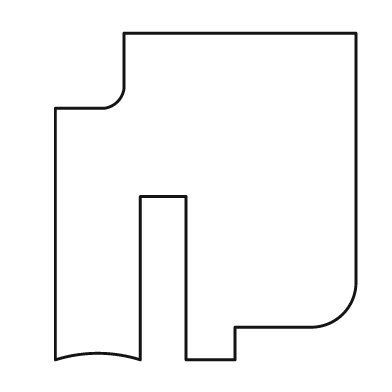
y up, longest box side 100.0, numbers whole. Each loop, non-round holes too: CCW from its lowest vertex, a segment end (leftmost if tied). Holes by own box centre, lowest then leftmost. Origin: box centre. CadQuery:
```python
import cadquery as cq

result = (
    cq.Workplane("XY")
    .moveTo(-46.0, -50.0)
    .threePointArc((-33.0, -48.0), (-20.0, -50.0))
    .lineTo(-20.0, 0.0)
    .lineTo(-6.0, 0.0)
    .lineTo(-6.0, -50.0)
    .lineTo(9.0, -50.0)
    .lineTo(9.0, -40.0)
    .lineTo(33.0, -40.0)
    .threePointArc((42.0, -36.0), (46.0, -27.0))
    .lineTo(46.0, 50.0)
    .lineTo(-25.0, 50.0)
    .lineTo(-25.0, 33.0)
    .threePointArc((-27.0, 29.0), (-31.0, 27.0))
    .lineTo(-46.0, 27.0)
    .close()
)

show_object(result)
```